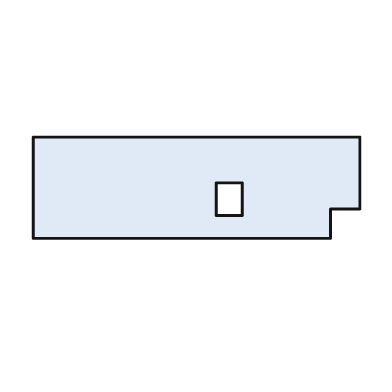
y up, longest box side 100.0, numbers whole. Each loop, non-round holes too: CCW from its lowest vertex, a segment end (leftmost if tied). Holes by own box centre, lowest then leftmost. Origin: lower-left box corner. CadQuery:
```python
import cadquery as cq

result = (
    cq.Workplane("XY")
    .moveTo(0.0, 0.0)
    .lineTo(91.0, 0.0)
    .lineTo(91.0, 9.0)
    .lineTo(100.0, 9.0)
    .lineTo(100.0, 31.0)
    .lineTo(0.0, 31.0)
    .close()
    .moveTo(56.0, 7.0)
    .lineTo(64.0, 7.0)
    .lineTo(64.0, 17.0)
    .lineTo(56.0, 17.0)
    .close()
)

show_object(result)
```